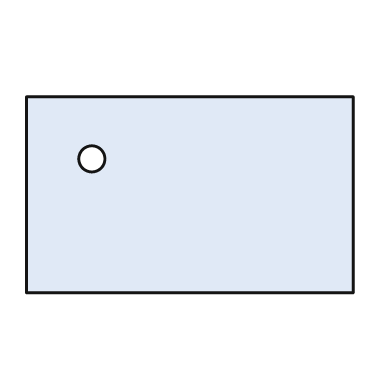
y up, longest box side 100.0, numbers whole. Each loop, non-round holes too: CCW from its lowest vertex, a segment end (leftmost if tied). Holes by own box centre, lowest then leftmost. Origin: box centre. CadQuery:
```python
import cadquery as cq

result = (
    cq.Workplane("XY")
    .moveTo(-50.0, -30.0)
    .lineTo(50.0, -30.0)
    .lineTo(50.0, 30.0)
    .lineTo(-50.0, 30.0)
    .close()
    .moveTo(-30.0, 11.0)
    .circle(4.0)
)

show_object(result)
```